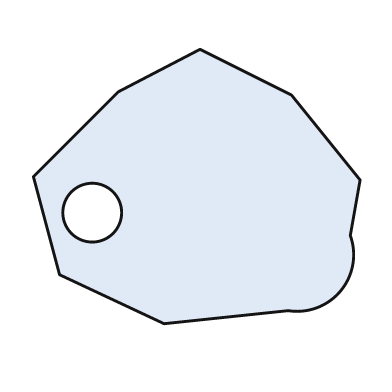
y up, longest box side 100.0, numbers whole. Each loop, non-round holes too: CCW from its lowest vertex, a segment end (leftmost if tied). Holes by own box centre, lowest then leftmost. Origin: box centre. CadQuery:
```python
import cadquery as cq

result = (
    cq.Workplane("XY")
    .moveTo(-10.0, -42.0)
    .lineTo(28.0, -38.0)
    .threePointArc((44.0, -32.0), (47.0, -15.0))
    .lineTo(50.0, 2.0)
    .lineTo(29.0, 28.0)
    .lineTo(1.0, 42.0)
    .lineTo(-24.0, 29.0)
    .lineTo(-50.0, 3.0)
    .lineTo(-42.0, -27.0)
    .close()
    .moveTo(-32.0, -8.0)
    .circle(9.0)
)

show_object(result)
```